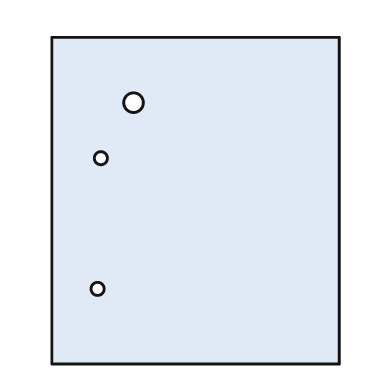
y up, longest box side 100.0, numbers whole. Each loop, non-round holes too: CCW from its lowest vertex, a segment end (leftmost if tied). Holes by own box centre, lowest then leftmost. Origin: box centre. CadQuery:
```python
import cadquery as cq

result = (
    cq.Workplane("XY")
    .moveTo(-44.0, -50.0)
    .lineTo(44.0, -50.0)
    .lineTo(44.0, 50.0)
    .lineTo(-44.0, 50.0)
    .close()
    .moveTo(-30.0, -27.0)
    .circle(2.0)
    .moveTo(-29.0, 13.0)
    .circle(2.0)
    .moveTo(-19.0, 30.0)
    .circle(3.0)
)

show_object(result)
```